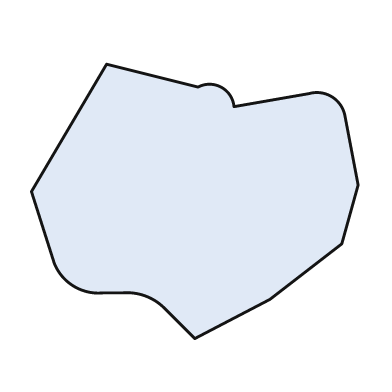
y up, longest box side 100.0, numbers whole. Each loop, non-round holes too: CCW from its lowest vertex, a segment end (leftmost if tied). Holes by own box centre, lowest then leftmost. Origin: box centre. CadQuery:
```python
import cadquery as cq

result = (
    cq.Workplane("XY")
    .moveTo(0.0, -42.0)
    .lineTo(23.0, -30.0)
    .lineTo(45.0, -13.0)
    .lineTo(50.0, 5.0)
    .lineTo(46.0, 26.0)
    .threePointArc((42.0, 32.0), (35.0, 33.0))
    .lineTo(12.0, 29.0)
    .threePointArc((8.0, 35.0), (1.0, 35.0))
    .lineTo(-27.0, 42.0)
    .lineTo(-50.0, 3.0)
    .lineTo(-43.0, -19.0)
    .threePointArc((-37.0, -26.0), (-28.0, -28.0))
    .lineTo(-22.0, -28.0)
    .threePointArc((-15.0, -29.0), (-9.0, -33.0))
    .close()
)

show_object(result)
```